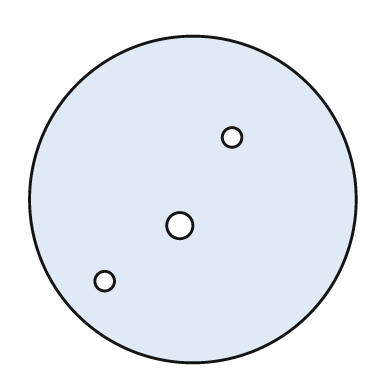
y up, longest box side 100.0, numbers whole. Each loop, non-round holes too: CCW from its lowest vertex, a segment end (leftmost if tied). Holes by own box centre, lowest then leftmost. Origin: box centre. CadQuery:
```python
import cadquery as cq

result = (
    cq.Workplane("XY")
    .moveTo(0.0, 0.0)
    .circle(50.0)
    .moveTo(-27.0, -25.0)
    .circle(3.0)
    .moveTo(-4.0, -8.0)
    .circle(4.0)
    .moveTo(12.0, 19.0)
    .circle(3.0)
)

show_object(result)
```